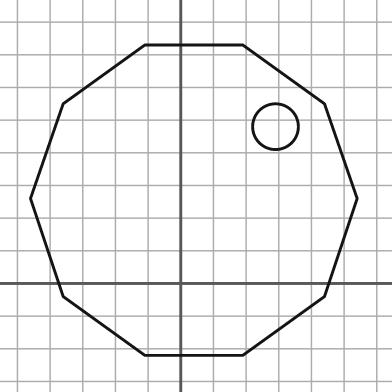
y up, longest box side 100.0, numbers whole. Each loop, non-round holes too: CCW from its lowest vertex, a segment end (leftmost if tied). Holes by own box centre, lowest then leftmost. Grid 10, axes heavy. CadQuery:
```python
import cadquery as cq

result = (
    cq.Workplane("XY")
    .moveTo(-11.0, -22.0)
    .lineTo(19.0, -22.0)
    .lineTo(44.0, -4.0)
    .lineTo(54.0, 26.0)
    .lineTo(44.0, 55.0)
    .lineTo(19.0, 73.0)
    .lineTo(-11.0, 73.0)
    .lineTo(-36.0, 55.0)
    .lineTo(-46.0, 26.0)
    .lineTo(-36.0, -4.0)
    .close()
    .moveTo(29.0, 48.0)
    .circle(7.0)
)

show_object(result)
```